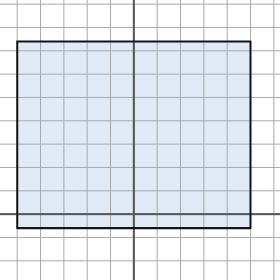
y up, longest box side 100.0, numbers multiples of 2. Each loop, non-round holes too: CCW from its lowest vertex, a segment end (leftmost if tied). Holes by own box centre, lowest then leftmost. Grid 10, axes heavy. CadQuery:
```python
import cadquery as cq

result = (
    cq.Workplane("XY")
    .moveTo(-50.0, -6.0)
    .lineTo(50.0, -6.0)
    .lineTo(50.0, 74.0)
    .lineTo(-50.0, 74.0)
    .close()
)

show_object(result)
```